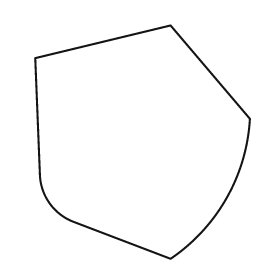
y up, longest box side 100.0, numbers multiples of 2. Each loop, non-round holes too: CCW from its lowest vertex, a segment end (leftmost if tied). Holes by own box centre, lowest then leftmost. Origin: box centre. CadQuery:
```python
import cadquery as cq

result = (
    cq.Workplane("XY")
    .moveTo(12.0, -50.0)
    .threePointArc((36.0, -24.0), (46.0, 10.0))
    .lineTo(12.0, 50.0)
    .lineTo(-46.0, 36.0)
    .lineTo(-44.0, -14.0)
    .threePointArc((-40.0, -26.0), (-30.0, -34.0))
    .close()
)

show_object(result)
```